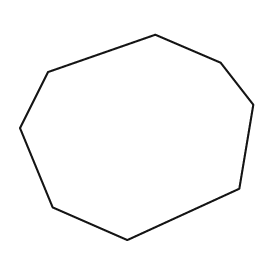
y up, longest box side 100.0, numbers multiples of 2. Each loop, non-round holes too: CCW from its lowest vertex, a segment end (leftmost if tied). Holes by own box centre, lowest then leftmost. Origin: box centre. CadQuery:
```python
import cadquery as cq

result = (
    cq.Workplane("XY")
    .moveTo(-4.0, -44.0)
    .lineTo(44.0, -22.0)
    .lineTo(50.0, 14.0)
    .lineTo(36.0, 32.0)
    .lineTo(8.0, 44.0)
    .lineTo(-38.0, 28.0)
    .lineTo(-50.0, 4.0)
    .lineTo(-36.0, -30.0)
    .close()
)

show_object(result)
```